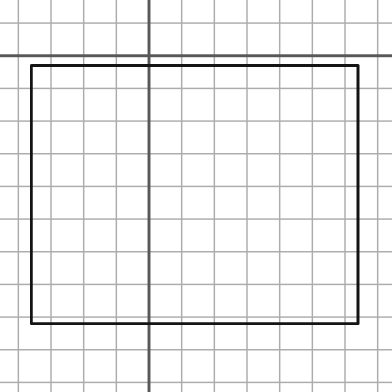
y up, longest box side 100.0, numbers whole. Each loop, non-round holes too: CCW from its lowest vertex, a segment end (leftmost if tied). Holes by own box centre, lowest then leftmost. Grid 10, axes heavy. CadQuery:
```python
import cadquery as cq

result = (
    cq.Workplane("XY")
    .moveTo(-36.0, -82.0)
    .lineTo(64.0, -82.0)
    .lineTo(64.0, -3.0)
    .lineTo(-36.0, -3.0)
    .close()
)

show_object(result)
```